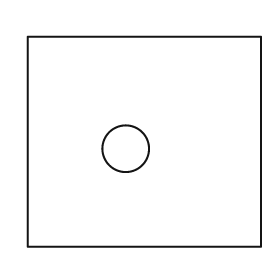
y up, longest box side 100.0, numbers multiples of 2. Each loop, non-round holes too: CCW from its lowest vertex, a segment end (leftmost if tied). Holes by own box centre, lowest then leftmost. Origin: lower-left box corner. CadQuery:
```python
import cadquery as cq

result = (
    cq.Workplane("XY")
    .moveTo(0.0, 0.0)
    .lineTo(100.0, 0.0)
    .lineTo(100.0, 90.0)
    .lineTo(0.0, 90.0)
    .close()
    .moveTo(42.0, 42.0)
    .circle(10.0)
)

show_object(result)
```